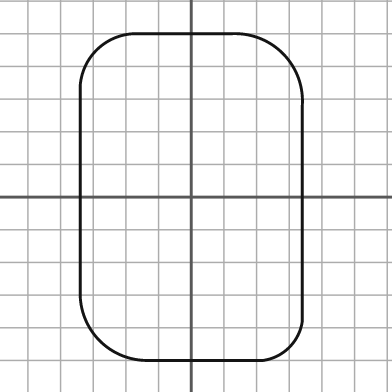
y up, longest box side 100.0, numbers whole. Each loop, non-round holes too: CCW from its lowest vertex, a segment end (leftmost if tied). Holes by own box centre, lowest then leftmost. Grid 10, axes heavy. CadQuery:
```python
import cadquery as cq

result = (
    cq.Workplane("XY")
    .moveTo(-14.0, -50.0)
    .lineTo(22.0, -50.0)
    .threePointArc((30.0, -46.0), (34.0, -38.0))
    .lineTo(34.0, 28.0)
    .threePointArc((28.0, 44.0), (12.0, 50.0))
    .lineTo(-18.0, 50.0)
    .threePointArc((-29.0, 45.0), (-34.0, 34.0))
    .lineTo(-34.0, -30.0)
    .threePointArc((-28.0, -44.0), (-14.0, -50.0))
    .close()
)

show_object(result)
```